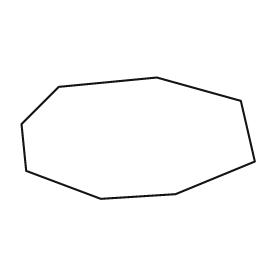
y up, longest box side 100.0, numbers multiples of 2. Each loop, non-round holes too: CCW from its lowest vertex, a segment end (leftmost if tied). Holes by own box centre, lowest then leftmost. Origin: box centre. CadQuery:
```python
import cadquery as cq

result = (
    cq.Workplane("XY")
    .moveTo(-16.0, -26.0)
    .lineTo(16.0, -24.0)
    .lineTo(50.0, -10.0)
    .lineTo(44.0, 16.0)
    .lineTo(8.0, 26.0)
    .lineTo(-34.0, 22.0)
    .lineTo(-50.0, 6.0)
    .lineTo(-48.0, -14.0)
    .close()
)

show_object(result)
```